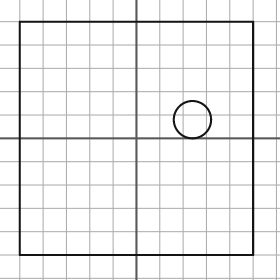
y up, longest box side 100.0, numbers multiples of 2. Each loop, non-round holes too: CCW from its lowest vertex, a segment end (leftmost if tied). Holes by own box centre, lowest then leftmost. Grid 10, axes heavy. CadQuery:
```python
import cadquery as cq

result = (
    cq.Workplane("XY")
    .moveTo(-50.0, -50.0)
    .lineTo(50.0, -50.0)
    .lineTo(50.0, 50.0)
    .lineTo(-50.0, 50.0)
    .close()
    .moveTo(24.0, 8.0)
    .circle(8.0)
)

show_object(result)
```